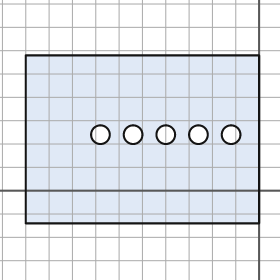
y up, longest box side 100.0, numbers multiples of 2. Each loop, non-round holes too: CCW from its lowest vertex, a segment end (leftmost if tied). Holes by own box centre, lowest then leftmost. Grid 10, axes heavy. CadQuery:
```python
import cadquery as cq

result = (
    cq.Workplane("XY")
    .moveTo(-100.0, -14.0)
    .lineTo(0.0, -14.0)
    .lineTo(0.0, 58.0)
    .lineTo(-100.0, 58.0)
    .close()
    .moveTo(-68.0, 24.0)
    .circle(4.0)
    .moveTo(-54.0, 24.0)
    .circle(4.0)
    .moveTo(-40.0, 24.0)
    .circle(4.0)
    .moveTo(-26.0, 24.0)
    .circle(4.0)
    .moveTo(-12.0, 24.0)
    .circle(4.0)
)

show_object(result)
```